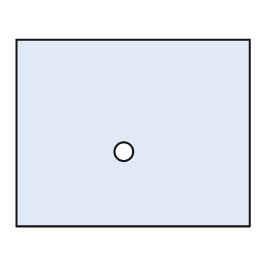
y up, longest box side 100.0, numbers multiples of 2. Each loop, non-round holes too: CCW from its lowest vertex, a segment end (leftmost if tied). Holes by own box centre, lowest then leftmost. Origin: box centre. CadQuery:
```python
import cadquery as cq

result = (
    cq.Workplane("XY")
    .moveTo(-50.0, -40.0)
    .lineTo(50.0, -40.0)
    .lineTo(50.0, 40.0)
    .lineTo(-50.0, 40.0)
    .close()
    .moveTo(-4.0, -8.0)
    .circle(4.0)
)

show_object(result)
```